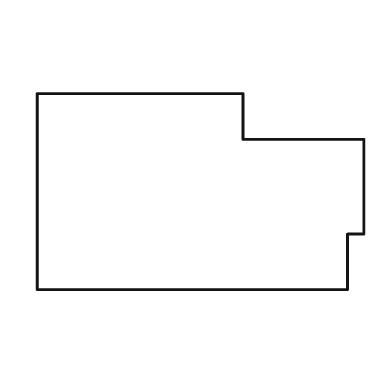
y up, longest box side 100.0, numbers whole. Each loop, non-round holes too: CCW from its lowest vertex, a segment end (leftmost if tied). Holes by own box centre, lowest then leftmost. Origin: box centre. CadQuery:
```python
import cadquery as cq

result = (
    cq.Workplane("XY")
    .moveTo(-50.0, -30.0)
    .lineTo(45.0, -30.0)
    .lineTo(45.0, -13.0)
    .lineTo(50.0, -13.0)
    .lineTo(50.0, 16.0)
    .lineTo(13.0, 16.0)
    .lineTo(13.0, 30.0)
    .lineTo(-50.0, 30.0)
    .close()
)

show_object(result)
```